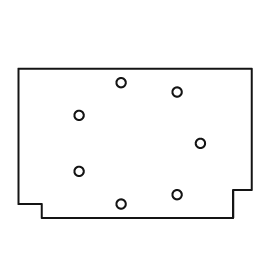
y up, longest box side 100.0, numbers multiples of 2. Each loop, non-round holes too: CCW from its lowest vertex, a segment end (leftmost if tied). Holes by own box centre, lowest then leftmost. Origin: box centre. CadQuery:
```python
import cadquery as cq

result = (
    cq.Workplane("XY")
    .moveTo(-40.0, -32.0)
    .lineTo(42.0, -32.0)
    .lineTo(42.0, -20.0)
    .lineTo(50.0, -20.0)
    .lineTo(50.0, 32.0)
    .lineTo(-50.0, 32.0)
    .lineTo(-50.0, -26.0)
    .lineTo(-40.0, -26.0)
    .close()
    .moveTo(-6.0, -26.0)
    .circle(2.0)
    .moveTo(18.0, -22.0)
    .circle(2.0)
    .moveTo(-24.0, -12.0)
    .circle(2.0)
    .moveTo(28.0, 0.0)
    .circle(2.0)
    .moveTo(-24.0, 12.0)
    .circle(2.0)
    .moveTo(18.0, 22.0)
    .circle(2.0)
    .moveTo(-6.0, 26.0)
    .circle(2.0)
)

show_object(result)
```